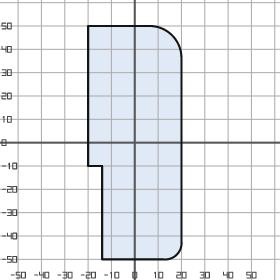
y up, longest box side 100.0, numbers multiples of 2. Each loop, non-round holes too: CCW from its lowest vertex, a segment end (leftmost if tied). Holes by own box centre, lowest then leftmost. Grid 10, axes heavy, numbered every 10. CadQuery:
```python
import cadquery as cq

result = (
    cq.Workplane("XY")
    .moveTo(-14.0, -50.0)
    .lineTo(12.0, -50.0)
    .threePointArc((18.0, -48.0), (20.0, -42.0))
    .lineTo(20.0, 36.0)
    .threePointArc((16.0, 46.0), (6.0, 50.0))
    .lineTo(-20.0, 50.0)
    .lineTo(-20.0, -10.0)
    .lineTo(-14.0, -10.0)
    .close()
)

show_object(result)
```